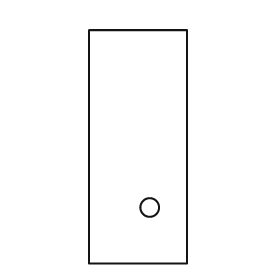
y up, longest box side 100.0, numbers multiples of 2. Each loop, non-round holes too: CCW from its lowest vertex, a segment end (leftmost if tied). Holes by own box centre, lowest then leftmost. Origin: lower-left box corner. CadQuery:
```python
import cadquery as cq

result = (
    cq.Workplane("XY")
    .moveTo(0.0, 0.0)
    .lineTo(42.0, 0.0)
    .lineTo(42.0, 100.0)
    .lineTo(0.0, 100.0)
    .close()
    .moveTo(26.0, 24.0)
    .circle(4.0)
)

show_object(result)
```